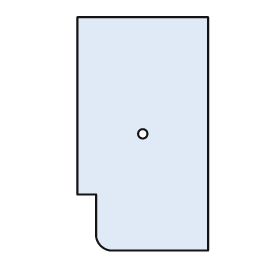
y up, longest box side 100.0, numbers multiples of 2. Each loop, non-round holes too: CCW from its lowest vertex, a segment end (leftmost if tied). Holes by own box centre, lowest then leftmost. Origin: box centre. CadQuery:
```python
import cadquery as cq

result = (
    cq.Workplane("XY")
    .moveTo(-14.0, -50.0)
    .lineTo(28.0, -50.0)
    .lineTo(28.0, 50.0)
    .lineTo(-28.0, 50.0)
    .lineTo(-28.0, -26.0)
    .lineTo(-20.0, -26.0)
    .lineTo(-20.0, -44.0)
    .threePointArc((-18.0, -48.0), (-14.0, -50.0))
    .close()
    .moveTo(0.0, 0.0)
    .circle(2.0)
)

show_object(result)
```